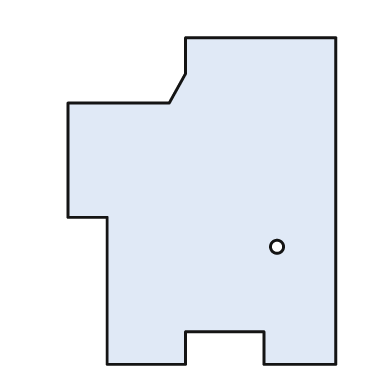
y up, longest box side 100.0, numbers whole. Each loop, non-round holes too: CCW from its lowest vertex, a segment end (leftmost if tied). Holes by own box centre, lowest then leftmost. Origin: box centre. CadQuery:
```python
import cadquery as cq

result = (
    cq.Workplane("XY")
    .moveTo(-29.0, -50.0)
    .lineTo(-5.0, -50.0)
    .lineTo(-5.0, -40.0)
    .lineTo(19.0, -40.0)
    .lineTo(19.0, -50.0)
    .lineTo(41.0, -50.0)
    .lineTo(41.0, 50.0)
    .lineTo(-5.0, 50.0)
    .lineTo(-5.0, 39.0)
    .lineTo(-10.0, 30.0)
    .lineTo(-41.0, 30.0)
    .lineTo(-41.0, -5.0)
    .lineTo(-29.0, -5.0)
    .close()
    .moveTo(23.0, -14.0)
    .circle(2.0)
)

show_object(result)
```